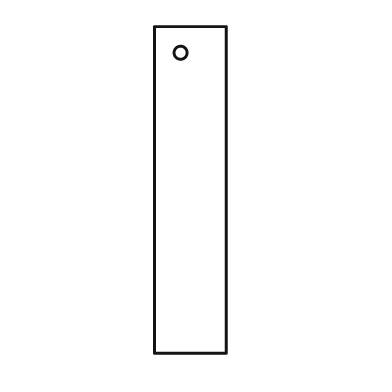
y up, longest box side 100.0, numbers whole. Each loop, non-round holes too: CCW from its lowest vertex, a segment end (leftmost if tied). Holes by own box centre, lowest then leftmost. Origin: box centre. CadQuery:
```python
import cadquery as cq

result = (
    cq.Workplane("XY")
    .moveTo(-11.0, -50.0)
    .lineTo(11.0, -50.0)
    .lineTo(11.0, 50.0)
    .lineTo(-11.0, 50.0)
    .close()
    .moveTo(-3.0, 42.0)
    .circle(2.0)
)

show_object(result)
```